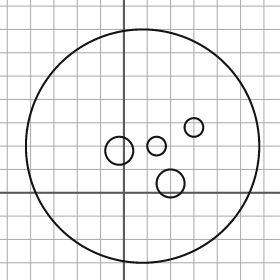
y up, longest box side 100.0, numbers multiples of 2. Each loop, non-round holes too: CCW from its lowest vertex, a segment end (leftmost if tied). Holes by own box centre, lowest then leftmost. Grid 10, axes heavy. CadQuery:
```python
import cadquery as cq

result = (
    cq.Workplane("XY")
    .moveTo(8.0, 20.0)
    .circle(50.0)
    .moveTo(20.0, 4.0)
    .circle(6.0)
    .moveTo(-2.0, 18.0)
    .circle(6.0)
    .moveTo(14.0, 20.0)
    .circle(4.0)
    .moveTo(30.0, 28.0)
    .circle(4.0)
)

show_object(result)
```